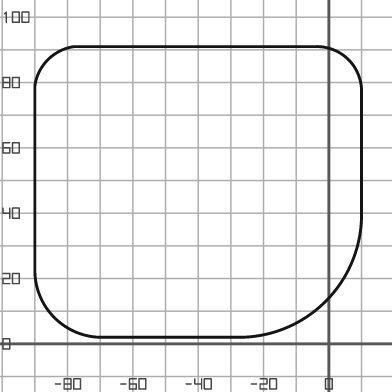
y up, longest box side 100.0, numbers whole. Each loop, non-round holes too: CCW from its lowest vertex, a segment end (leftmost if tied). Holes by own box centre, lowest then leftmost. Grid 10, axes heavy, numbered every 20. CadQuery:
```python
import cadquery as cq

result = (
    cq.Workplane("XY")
    .moveTo(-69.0, 2.0)
    .lineTo(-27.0, 2.0)
    .threePointArc((-1.0, 13.0), (10.0, 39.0))
    .lineTo(10.0, 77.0)
    .threePointArc((6.0, 87.0), (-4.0, 91.0))
    .lineTo(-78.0, 91.0)
    .threePointArc((-86.0, 87.0), (-90.0, 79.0))
    .lineTo(-90.0, 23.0)
    .threePointArc((-84.0, 8.0), (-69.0, 2.0))
    .close()
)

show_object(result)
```